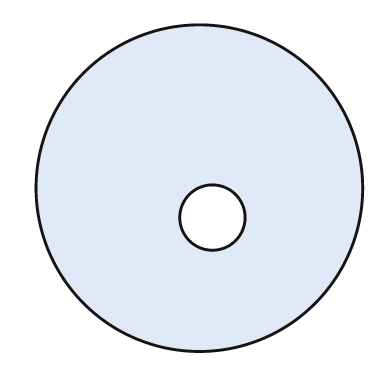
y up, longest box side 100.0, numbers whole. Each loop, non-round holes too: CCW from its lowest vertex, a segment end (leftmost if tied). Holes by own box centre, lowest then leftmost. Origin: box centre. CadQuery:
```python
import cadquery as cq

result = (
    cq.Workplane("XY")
    .moveTo(0.0, 0.0)
    .circle(50.0)
    .moveTo(4.0, -9.0)
    .circle(10.0)
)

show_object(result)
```